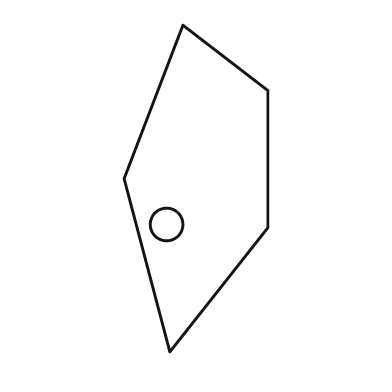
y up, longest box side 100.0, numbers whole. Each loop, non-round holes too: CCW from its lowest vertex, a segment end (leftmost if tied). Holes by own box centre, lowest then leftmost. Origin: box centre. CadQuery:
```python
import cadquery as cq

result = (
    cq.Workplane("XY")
    .moveTo(-8.0, -50.0)
    .lineTo(22.0, -12.0)
    .lineTo(22.0, 30.0)
    .lineTo(-4.0, 50.0)
    .lineTo(-22.0, 3.0)
    .close()
    .moveTo(-9.0, -11.0)
    .circle(5.0)
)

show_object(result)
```